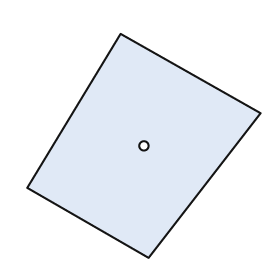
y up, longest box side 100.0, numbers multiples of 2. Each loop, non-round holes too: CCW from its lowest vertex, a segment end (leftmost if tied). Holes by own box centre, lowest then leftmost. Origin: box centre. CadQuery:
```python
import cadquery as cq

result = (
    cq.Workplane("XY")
    .moveTo(2.0, -48.0)
    .lineTo(50.0, 14.0)
    .lineTo(-10.0, 48.0)
    .lineTo(-50.0, -18.0)
    .close()
    .moveTo(0.0, 0.0)
    .circle(2.0)
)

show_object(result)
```